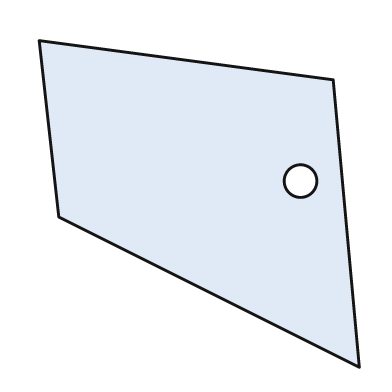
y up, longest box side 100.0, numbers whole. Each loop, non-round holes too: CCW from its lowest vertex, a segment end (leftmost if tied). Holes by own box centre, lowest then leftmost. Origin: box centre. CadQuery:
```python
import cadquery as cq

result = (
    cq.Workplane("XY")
    .moveTo(49.0, -50.0)
    .lineTo(41.0, 38.0)
    .lineTo(-49.0, 50.0)
    .lineTo(-43.0, -4.0)
    .close()
    .moveTo(31.0, 7.0)
    .circle(5.0)
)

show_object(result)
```